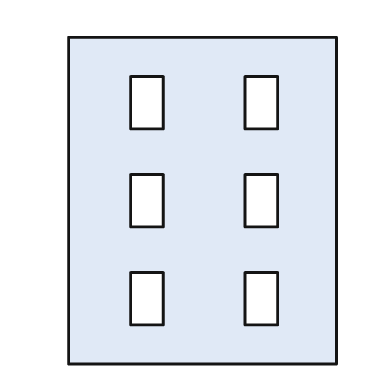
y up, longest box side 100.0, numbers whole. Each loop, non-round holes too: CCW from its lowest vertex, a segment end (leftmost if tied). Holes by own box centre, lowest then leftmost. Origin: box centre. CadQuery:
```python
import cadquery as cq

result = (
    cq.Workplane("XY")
    .moveTo(-41.0, -50.0)
    .lineTo(41.0, -50.0)
    .lineTo(41.0, 50.0)
    .lineTo(-41.0, 50.0)
    .close()
    .moveTo(-22.0, -38.0)
    .lineTo(-12.0, -38.0)
    .lineTo(-12.0, -22.0)
    .lineTo(-22.0, -22.0)
    .close()
    .moveTo(13.0, -38.0)
    .lineTo(23.0, -38.0)
    .lineTo(23.0, -22.0)
    .lineTo(13.0, -22.0)
    .close()
    .moveTo(-22.0, -8.0)
    .lineTo(-12.0, -8.0)
    .lineTo(-12.0, 8.0)
    .lineTo(-22.0, 8.0)
    .close()
    .moveTo(13.0, -8.0)
    .lineTo(23.0, -8.0)
    .lineTo(23.0, 8.0)
    .lineTo(13.0, 8.0)
    .close()
    .moveTo(-22.0, 22.0)
    .lineTo(-12.0, 22.0)
    .lineTo(-12.0, 38.0)
    .lineTo(-22.0, 38.0)
    .close()
    .moveTo(13.0, 22.0)
    .lineTo(23.0, 22.0)
    .lineTo(23.0, 38.0)
    .lineTo(13.0, 38.0)
    .close()
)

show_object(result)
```